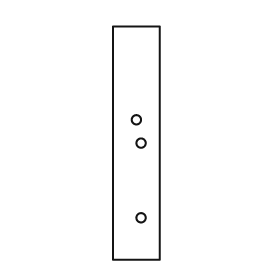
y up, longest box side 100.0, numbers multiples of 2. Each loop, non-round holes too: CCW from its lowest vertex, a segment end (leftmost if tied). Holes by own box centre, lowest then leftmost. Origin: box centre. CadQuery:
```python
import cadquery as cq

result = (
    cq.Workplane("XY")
    .moveTo(-10.0, -50.0)
    .lineTo(10.0, -50.0)
    .lineTo(10.0, 50.0)
    .lineTo(-10.0, 50.0)
    .close()
    .moveTo(2.0, -32.0)
    .circle(2.0)
    .moveTo(2.0, 0.0)
    .circle(2.0)
    .moveTo(0.0, 10.0)
    .circle(2.0)
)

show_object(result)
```